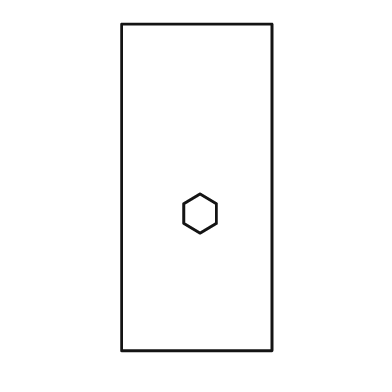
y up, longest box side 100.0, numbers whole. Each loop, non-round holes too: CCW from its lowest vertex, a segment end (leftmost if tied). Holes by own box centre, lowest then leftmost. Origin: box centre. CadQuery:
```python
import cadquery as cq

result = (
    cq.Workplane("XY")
    .moveTo(-23.0, -50.0)
    .lineTo(23.0, -50.0)
    .lineTo(23.0, 50.0)
    .lineTo(-23.0, 50.0)
    .close()
    .moveTo(1.0, -14.0)
    .lineTo(6.0, -11.0)
    .lineTo(6.0, -5.0)
    .lineTo(1.0, -2.0)
    .lineTo(-4.0, -5.0)
    .lineTo(-4.0, -11.0)
    .close()
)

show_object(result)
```